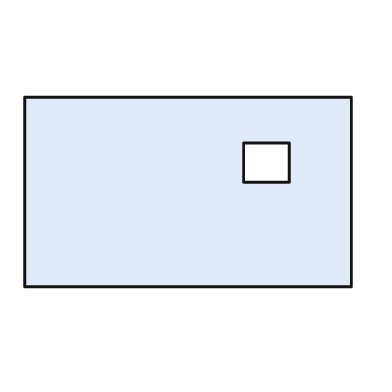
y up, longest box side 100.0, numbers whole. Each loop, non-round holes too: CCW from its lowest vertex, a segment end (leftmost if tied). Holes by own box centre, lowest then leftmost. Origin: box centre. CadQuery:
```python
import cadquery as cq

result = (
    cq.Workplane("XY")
    .moveTo(-50.0, -29.0)
    .lineTo(50.0, -29.0)
    .lineTo(50.0, 29.0)
    .lineTo(-50.0, 29.0)
    .close()
    .moveTo(17.0, 3.0)
    .lineTo(31.0, 3.0)
    .lineTo(31.0, 15.0)
    .lineTo(17.0, 15.0)
    .close()
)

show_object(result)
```